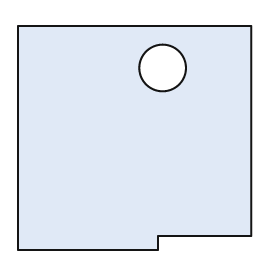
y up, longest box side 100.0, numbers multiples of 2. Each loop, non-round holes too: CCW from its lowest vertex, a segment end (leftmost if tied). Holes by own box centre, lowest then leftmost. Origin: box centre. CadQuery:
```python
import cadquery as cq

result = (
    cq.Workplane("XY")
    .moveTo(-50.0, -48.0)
    .lineTo(10.0, -48.0)
    .lineTo(10.0, -42.0)
    .lineTo(50.0, -42.0)
    .lineTo(50.0, 48.0)
    .lineTo(-50.0, 48.0)
    .close()
    .moveTo(12.0, 30.0)
    .circle(10.0)
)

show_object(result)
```